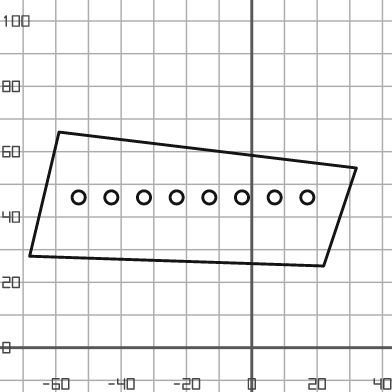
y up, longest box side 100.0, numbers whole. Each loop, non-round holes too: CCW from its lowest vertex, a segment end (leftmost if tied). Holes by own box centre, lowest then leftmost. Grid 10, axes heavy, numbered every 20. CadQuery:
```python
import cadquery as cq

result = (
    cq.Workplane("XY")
    .moveTo(22.0, 25.0)
    .lineTo(32.0, 55.0)
    .lineTo(-59.0, 66.0)
    .lineTo(-68.0, 28.0)
    .close()
    .moveTo(-53.0, 46.0)
    .circle(2.0)
    .moveTo(-43.0, 46.0)
    .circle(2.0)
    .moveTo(-33.0, 46.0)
    .circle(2.0)
    .moveTo(-23.0, 46.0)
    .circle(2.0)
    .moveTo(-13.0, 46.0)
    .circle(2.0)
    .moveTo(-3.0, 46.0)
    .circle(2.0)
    .moveTo(7.0, 46.0)
    .circle(2.0)
    .moveTo(17.0, 46.0)
    .circle(2.0)
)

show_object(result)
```